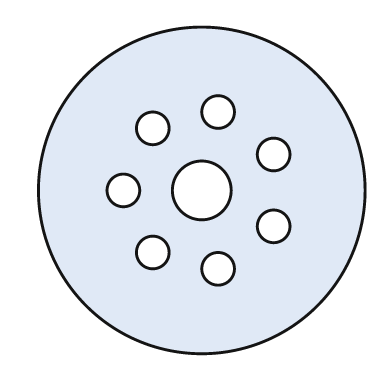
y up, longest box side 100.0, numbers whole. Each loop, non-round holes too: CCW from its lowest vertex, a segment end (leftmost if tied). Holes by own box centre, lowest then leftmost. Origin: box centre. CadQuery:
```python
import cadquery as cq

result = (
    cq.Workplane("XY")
    .moveTo(0.0, 0.0)
    .circle(50.0)
    .moveTo(5.0, -24.0)
    .circle(5.0)
    .moveTo(-15.0, -19.0)
    .circle(5.0)
    .moveTo(22.0, -11.0)
    .circle(5.0)
    .moveTo(-24.0, 0.0)
    .circle(5.0)
    .moveTo(0.0, 0.0)
    .circle(9.0)
    .moveTo(22.0, 11.0)
    .circle(5.0)
    .moveTo(-15.0, 19.0)
    .circle(5.0)
    .moveTo(5.0, 24.0)
    .circle(5.0)
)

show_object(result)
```